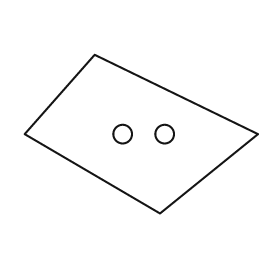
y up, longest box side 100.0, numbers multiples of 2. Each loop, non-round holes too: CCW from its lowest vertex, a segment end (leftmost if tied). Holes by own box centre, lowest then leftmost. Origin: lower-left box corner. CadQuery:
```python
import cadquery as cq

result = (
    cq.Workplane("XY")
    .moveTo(58.0, 0.0)
    .lineTo(100.0, 34.0)
    .lineTo(30.0, 68.0)
    .lineTo(0.0, 34.0)
    .close()
    .moveTo(42.0, 34.0)
    .circle(4.0)
    .moveTo(60.0, 34.0)
    .circle(4.0)
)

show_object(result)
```